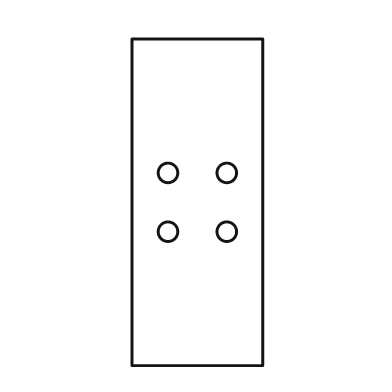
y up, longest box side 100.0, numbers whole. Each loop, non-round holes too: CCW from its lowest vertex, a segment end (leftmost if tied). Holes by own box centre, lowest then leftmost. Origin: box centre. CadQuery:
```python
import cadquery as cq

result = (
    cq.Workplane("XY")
    .moveTo(-20.0, -50.0)
    .lineTo(20.0, -50.0)
    .lineTo(20.0, 50.0)
    .lineTo(-20.0, 50.0)
    .close()
    .moveTo(-9.0, -9.0)
    .circle(3.0)
    .moveTo(9.0, -9.0)
    .circle(3.0)
    .moveTo(-9.0, 9.0)
    .circle(3.0)
    .moveTo(9.0, 9.0)
    .circle(3.0)
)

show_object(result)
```